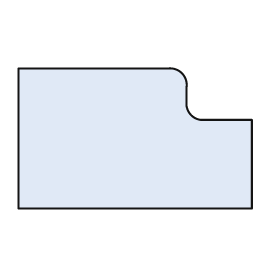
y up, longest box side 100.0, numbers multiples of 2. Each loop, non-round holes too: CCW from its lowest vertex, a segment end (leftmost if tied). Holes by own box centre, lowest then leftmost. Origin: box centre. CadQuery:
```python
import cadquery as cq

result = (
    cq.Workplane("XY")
    .moveTo(-50.0, -30.0)
    .lineTo(50.0, -30.0)
    .lineTo(50.0, 8.0)
    .lineTo(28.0, 8.0)
    .threePointArc((24.0, 10.0), (22.0, 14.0))
    .lineTo(22.0, 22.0)
    .threePointArc((20.0, 28.0), (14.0, 30.0))
    .lineTo(-50.0, 30.0)
    .close()
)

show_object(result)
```